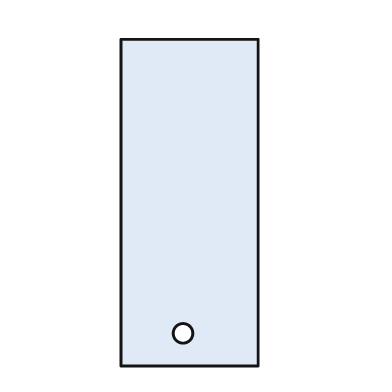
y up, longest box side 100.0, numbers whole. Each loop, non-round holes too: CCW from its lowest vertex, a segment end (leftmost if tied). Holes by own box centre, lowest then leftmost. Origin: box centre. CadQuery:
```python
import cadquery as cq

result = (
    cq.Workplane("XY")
    .moveTo(-21.0, -50.0)
    .lineTo(21.0, -50.0)
    .lineTo(21.0, 50.0)
    .lineTo(-21.0, 50.0)
    .close()
    .moveTo(-2.0, -40.0)
    .circle(3.0)
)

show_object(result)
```